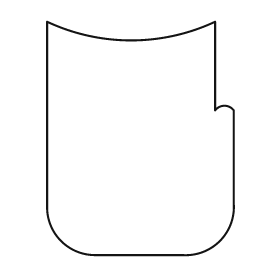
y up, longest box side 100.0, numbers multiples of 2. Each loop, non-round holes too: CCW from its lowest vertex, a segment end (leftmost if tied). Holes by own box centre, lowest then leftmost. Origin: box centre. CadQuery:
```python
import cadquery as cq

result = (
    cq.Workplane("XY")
    .moveTo(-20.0, -50.0)
    .lineTo(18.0, -50.0)
    .threePointArc((34.0, -44.0), (40.0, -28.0))
    .lineTo(40.0, 12.0)
    .threePointArc((36.0, 14.0), (32.0, 12.0))
    .lineTo(32.0, 50.0)
    .threePointArc((-4.0, 42.0), (-40.0, 50.0))
    .lineTo(-40.0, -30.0)
    .threePointArc((-34.0, -44.0), (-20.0, -50.0))
    .close()
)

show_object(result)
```